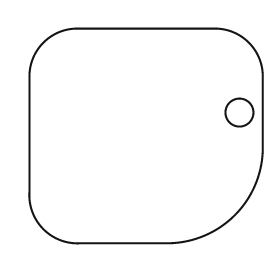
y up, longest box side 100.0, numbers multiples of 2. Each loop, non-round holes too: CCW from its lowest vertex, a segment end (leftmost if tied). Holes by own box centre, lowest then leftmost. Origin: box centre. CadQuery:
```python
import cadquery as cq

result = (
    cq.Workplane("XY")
    .moveTo(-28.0, -46.0)
    .lineTo(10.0, -46.0)
    .threePointArc((38.0, -34.0), (50.0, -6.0))
    .lineTo(50.0, 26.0)
    .threePointArc((44.0, 40.0), (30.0, 46.0))
    .lineTo(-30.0, 46.0)
    .threePointArc((-44.0, 40.0), (-50.0, 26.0))
    .lineTo(-50.0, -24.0)
    .threePointArc((-44.0, -40.0), (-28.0, -46.0))
    .close()
    .moveTo(40.0, 10.0)
    .circle(6.0)
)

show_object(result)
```